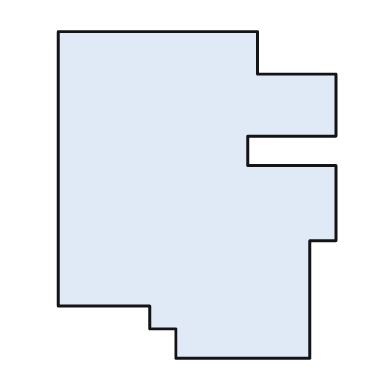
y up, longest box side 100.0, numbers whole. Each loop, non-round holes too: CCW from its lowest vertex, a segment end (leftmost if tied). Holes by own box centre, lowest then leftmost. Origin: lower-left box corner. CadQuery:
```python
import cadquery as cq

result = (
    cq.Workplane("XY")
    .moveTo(36.0, 0.0)
    .lineTo(77.0, 0.0)
    .lineTo(77.0, 36.0)
    .lineTo(85.0, 36.0)
    .lineTo(85.0, 59.0)
    .lineTo(58.0, 59.0)
    .lineTo(58.0, 68.0)
    .lineTo(85.0, 68.0)
    .lineTo(85.0, 87.0)
    .lineTo(61.0, 87.0)
    .lineTo(61.0, 100.0)
    .lineTo(0.0, 100.0)
    .lineTo(0.0, 16.0)
    .lineTo(28.0, 16.0)
    .lineTo(28.0, 9.0)
    .lineTo(36.0, 9.0)
    .close()
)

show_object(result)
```